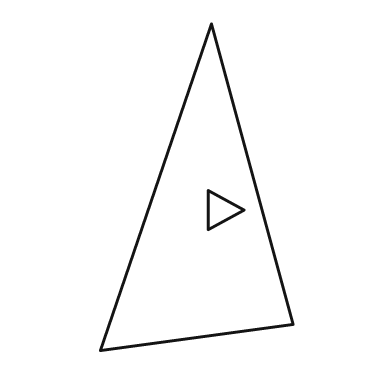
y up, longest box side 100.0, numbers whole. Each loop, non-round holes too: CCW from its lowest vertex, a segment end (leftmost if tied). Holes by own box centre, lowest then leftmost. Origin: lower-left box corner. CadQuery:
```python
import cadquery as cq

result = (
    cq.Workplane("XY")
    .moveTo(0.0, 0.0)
    .lineTo(59.0, 8.0)
    .lineTo(34.0, 100.0)
    .close()
    .moveTo(33.0, 37.0)
    .lineTo(44.0, 43.0)
    .lineTo(33.0, 49.0)
    .close()
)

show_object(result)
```